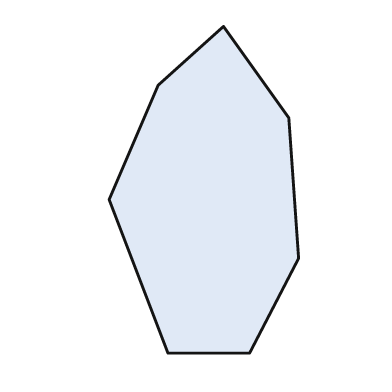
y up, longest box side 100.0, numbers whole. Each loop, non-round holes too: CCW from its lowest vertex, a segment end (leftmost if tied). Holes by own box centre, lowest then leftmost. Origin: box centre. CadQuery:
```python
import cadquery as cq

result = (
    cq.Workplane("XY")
    .moveTo(-11.0, -50.0)
    .lineTo(14.0, -50.0)
    .lineTo(29.0, -21.0)
    .lineTo(26.0, 22.0)
    .lineTo(6.0, 50.0)
    .lineTo(-14.0, 32.0)
    .lineTo(-29.0, -3.0)
    .close()
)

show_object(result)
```